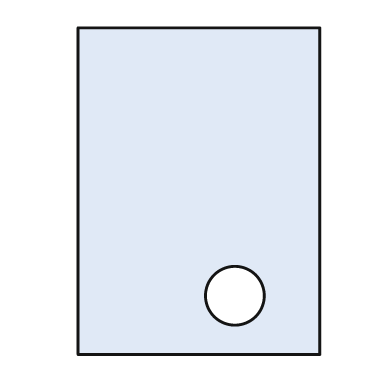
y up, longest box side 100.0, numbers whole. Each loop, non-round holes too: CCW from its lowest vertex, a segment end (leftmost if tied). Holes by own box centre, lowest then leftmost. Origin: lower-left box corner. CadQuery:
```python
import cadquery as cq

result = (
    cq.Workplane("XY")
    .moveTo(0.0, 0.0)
    .lineTo(74.0, 0.0)
    .lineTo(74.0, 100.0)
    .lineTo(0.0, 100.0)
    .close()
    .moveTo(48.0, 18.0)
    .circle(9.0)
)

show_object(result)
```